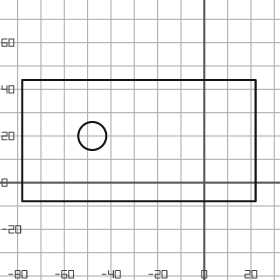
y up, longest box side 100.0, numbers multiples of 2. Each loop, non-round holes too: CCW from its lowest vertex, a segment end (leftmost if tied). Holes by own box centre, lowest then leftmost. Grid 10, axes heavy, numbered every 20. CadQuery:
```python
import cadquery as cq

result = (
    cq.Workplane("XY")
    .moveTo(-78.0, -8.0)
    .lineTo(22.0, -8.0)
    .lineTo(22.0, 44.0)
    .lineTo(-78.0, 44.0)
    .close()
    .moveTo(-48.0, 20.0)
    .circle(6.0)
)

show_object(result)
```